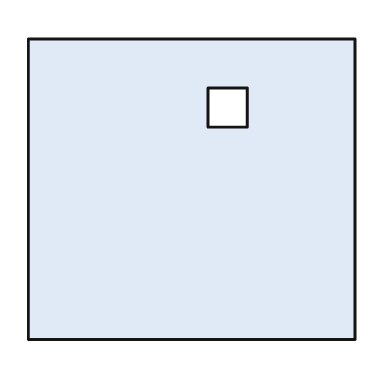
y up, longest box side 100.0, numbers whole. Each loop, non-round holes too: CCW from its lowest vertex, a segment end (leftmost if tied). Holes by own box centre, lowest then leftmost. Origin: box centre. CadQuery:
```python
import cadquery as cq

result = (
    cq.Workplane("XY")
    .moveTo(-50.0, -46.0)
    .lineTo(50.0, -46.0)
    .lineTo(50.0, 46.0)
    .lineTo(-50.0, 46.0)
    .close()
    .moveTo(5.0, 19.0)
    .lineTo(17.0, 19.0)
    .lineTo(17.0, 31.0)
    .lineTo(5.0, 31.0)
    .close()
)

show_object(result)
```